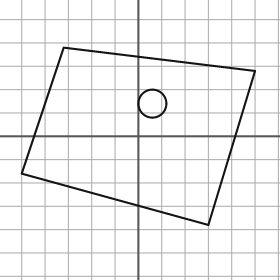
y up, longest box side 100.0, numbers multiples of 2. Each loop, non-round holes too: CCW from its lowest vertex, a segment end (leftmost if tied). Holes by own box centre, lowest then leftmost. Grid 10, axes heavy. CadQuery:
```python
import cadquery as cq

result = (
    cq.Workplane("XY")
    .moveTo(30.0, -38.0)
    .lineTo(50.0, 28.0)
    .lineTo(-32.0, 38.0)
    .lineTo(-50.0, -16.0)
    .close()
    .moveTo(6.0, 14.0)
    .circle(6.0)
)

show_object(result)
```